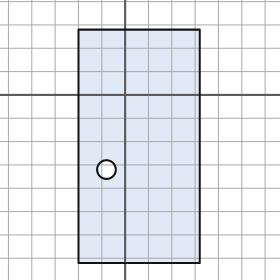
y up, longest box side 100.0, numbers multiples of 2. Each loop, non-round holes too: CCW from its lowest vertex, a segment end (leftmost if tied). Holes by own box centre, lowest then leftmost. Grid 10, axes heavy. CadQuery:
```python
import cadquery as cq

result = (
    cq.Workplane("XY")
    .moveTo(-20.0, -72.0)
    .lineTo(32.0, -72.0)
    .lineTo(32.0, 28.0)
    .lineTo(-20.0, 28.0)
    .close()
    .moveTo(-8.0, -32.0)
    .circle(4.0)
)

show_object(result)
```